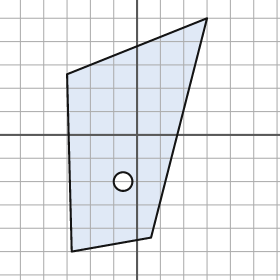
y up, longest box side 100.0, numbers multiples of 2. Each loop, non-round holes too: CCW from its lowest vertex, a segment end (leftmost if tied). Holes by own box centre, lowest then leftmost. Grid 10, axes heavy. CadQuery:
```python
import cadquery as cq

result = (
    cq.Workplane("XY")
    .moveTo(-28.0, -50.0)
    .lineTo(6.0, -44.0)
    .lineTo(30.0, 50.0)
    .lineTo(-30.0, 26.0)
    .close()
    .moveTo(-6.0, -20.0)
    .circle(4.0)
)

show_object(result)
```